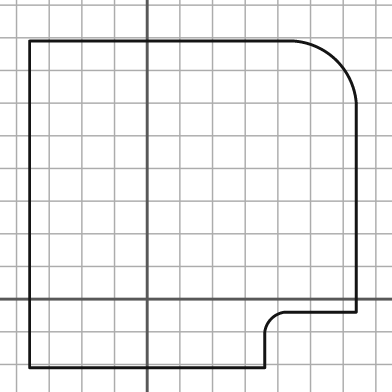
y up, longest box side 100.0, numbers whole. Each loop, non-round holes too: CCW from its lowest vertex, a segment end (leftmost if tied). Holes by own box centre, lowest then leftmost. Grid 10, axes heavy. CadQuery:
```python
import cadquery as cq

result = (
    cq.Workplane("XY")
    .moveTo(-36.0, -21.0)
    .lineTo(36.0, -21.0)
    .lineTo(36.0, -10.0)
    .threePointArc((38.0, -6.0), (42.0, -4.0))
    .lineTo(64.0, -4.0)
    .lineTo(64.0, 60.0)
    .threePointArc((58.0, 73.0), (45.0, 79.0))
    .lineTo(-36.0, 79.0)
    .close()
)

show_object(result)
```